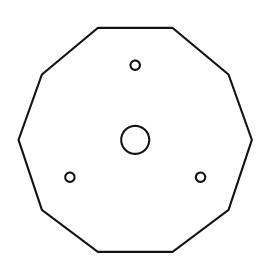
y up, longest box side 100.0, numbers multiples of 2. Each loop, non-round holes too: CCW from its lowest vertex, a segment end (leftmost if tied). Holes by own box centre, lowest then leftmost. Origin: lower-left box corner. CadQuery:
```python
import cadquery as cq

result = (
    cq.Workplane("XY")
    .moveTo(34.0, 0.0)
    .lineTo(66.0, 0.0)
    .lineTo(90.0, 18.0)
    .lineTo(100.0, 48.0)
    .lineTo(90.0, 76.0)
    .lineTo(66.0, 96.0)
    .lineTo(34.0, 96.0)
    .lineTo(10.0, 76.0)
    .lineTo(0.0, 48.0)
    .lineTo(10.0, 18.0)
    .close()
    .moveTo(22.0, 32.0)
    .circle(2.0)
    .moveTo(78.0, 32.0)
    .circle(2.0)
    .moveTo(50.0, 48.0)
    .circle(6.0)
    .moveTo(50.0, 80.0)
    .circle(2.0)
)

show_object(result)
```